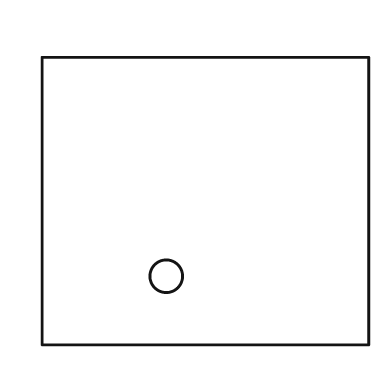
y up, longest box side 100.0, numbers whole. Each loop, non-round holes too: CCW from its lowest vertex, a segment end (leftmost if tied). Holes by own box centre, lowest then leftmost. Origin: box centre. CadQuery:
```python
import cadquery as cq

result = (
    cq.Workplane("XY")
    .moveTo(-50.0, -44.0)
    .lineTo(50.0, -44.0)
    .lineTo(50.0, 44.0)
    .lineTo(-50.0, 44.0)
    .close()
    .moveTo(-12.0, -23.0)
    .circle(5.0)
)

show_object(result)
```